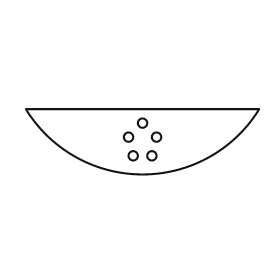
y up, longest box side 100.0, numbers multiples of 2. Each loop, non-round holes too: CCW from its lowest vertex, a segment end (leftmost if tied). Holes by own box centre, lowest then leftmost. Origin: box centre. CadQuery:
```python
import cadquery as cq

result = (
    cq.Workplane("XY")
    .moveTo(-50.0, 14.0)
    .threePointArc((0.0, -14.0), (50.0, 14.0))
    .close()
    .moveTo(-4.0, -6.0)
    .circle(2.0)
    .moveTo(4.0, -6.0)
    .circle(2.0)
    .moveTo(-6.0, 2.0)
    .circle(2.0)
    .moveTo(6.0, 2.0)
    .circle(2.0)
    .moveTo(0.0, 8.0)
    .circle(2.0)
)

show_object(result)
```